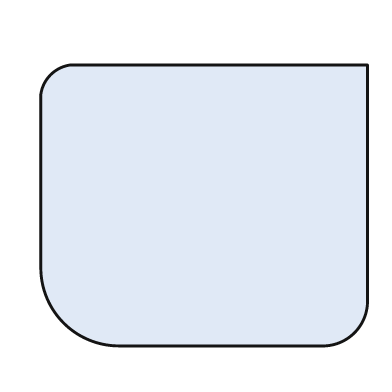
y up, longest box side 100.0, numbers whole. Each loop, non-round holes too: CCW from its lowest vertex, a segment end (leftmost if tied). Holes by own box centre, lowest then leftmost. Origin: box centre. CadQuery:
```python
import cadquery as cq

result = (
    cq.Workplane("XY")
    .moveTo(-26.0, -43.0)
    .lineTo(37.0, -43.0)
    .threePointArc((46.0, -39.0), (50.0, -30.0))
    .lineTo(50.0, 43.0)
    .lineTo(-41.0, 43.0)
    .threePointArc((-47.0, 40.0), (-50.0, 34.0))
    .lineTo(-50.0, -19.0)
    .threePointArc((-43.0, -36.0), (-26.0, -43.0))
    .close()
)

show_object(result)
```